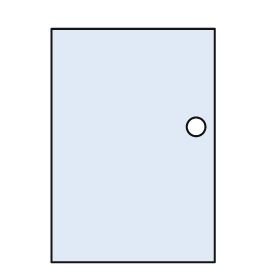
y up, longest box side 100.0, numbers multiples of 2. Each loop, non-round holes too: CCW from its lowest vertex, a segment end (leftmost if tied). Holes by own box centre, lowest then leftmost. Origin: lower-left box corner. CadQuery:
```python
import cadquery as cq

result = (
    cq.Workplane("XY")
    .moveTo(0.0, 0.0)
    .lineTo(70.0, 0.0)
    .lineTo(70.0, 100.0)
    .lineTo(0.0, 100.0)
    .close()
    .moveTo(62.0, 58.0)
    .circle(4.0)
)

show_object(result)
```